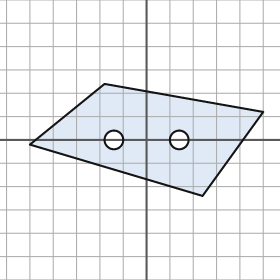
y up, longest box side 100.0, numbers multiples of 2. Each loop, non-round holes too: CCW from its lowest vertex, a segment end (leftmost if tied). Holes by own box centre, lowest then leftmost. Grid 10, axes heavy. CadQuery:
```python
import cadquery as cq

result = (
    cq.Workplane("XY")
    .moveTo(24.0, -24.0)
    .lineTo(50.0, 12.0)
    .lineTo(-18.0, 24.0)
    .lineTo(-50.0, -2.0)
    .close()
    .moveTo(-14.0, 0.0)
    .circle(4.0)
    .moveTo(14.0, 0.0)
    .circle(4.0)
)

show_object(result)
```